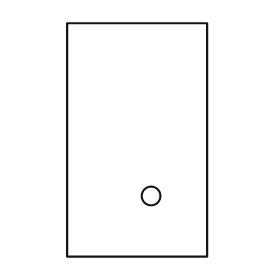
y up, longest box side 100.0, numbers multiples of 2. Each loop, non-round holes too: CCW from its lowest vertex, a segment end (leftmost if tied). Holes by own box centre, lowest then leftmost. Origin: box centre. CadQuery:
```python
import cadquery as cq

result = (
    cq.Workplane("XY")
    .moveTo(-30.0, -50.0)
    .lineTo(30.0, -50.0)
    .lineTo(30.0, 50.0)
    .lineTo(-30.0, 50.0)
    .close()
    .moveTo(6.0, -24.0)
    .circle(4.0)
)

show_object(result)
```